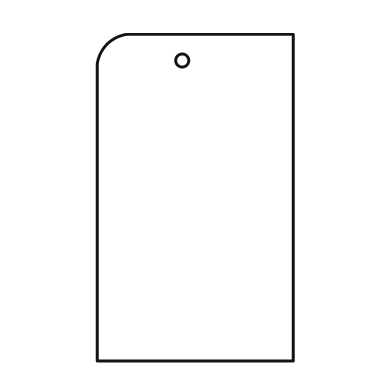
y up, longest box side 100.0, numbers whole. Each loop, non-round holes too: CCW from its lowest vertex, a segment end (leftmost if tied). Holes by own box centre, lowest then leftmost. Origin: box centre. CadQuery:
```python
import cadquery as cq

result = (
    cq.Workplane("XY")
    .moveTo(-30.0, -50.0)
    .lineTo(30.0, -50.0)
    .lineTo(30.0, 50.0)
    .lineTo(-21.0, 50.0)
    .threePointArc((-27.0, 47.0), (-30.0, 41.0))
    .close()
    .moveTo(-4.0, 42.0)
    .circle(2.0)
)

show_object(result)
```